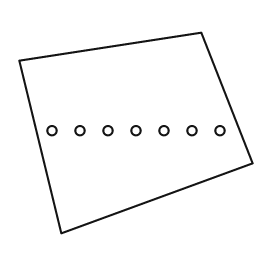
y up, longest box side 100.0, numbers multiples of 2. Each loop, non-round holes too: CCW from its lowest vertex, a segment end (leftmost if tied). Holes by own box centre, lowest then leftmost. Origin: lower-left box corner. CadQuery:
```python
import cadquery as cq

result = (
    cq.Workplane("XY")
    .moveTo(18.0, 0.0)
    .lineTo(100.0, 30.0)
    .lineTo(78.0, 86.0)
    .lineTo(0.0, 74.0)
    .close()
    .moveTo(14.0, 44.0)
    .circle(2.0)
    .moveTo(26.0, 44.0)
    .circle(2.0)
    .moveTo(38.0, 44.0)
    .circle(2.0)
    .moveTo(50.0, 44.0)
    .circle(2.0)
    .moveTo(62.0, 44.0)
    .circle(2.0)
    .moveTo(74.0, 44.0)
    .circle(2.0)
    .moveTo(86.0, 44.0)
    .circle(2.0)
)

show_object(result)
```